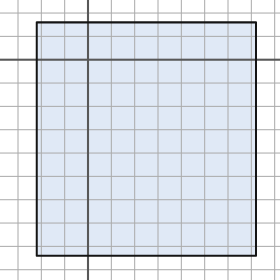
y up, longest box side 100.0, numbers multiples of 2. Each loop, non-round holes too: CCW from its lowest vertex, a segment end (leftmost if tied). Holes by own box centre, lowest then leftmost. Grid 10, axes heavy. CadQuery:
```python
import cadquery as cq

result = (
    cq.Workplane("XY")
    .moveTo(-22.0, -84.0)
    .lineTo(72.0, -84.0)
    .lineTo(72.0, 16.0)
    .lineTo(-22.0, 16.0)
    .close()
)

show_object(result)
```